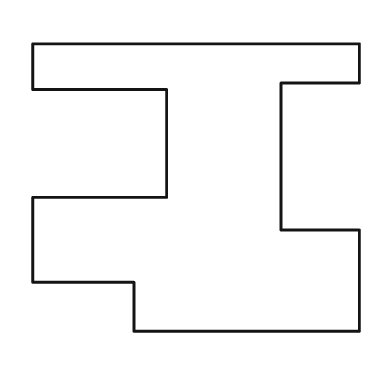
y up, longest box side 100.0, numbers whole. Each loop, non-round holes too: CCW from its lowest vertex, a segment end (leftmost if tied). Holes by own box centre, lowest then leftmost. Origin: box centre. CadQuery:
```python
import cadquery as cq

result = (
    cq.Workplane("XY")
    .moveTo(-19.0, -44.0)
    .lineTo(50.0, -44.0)
    .lineTo(50.0, -13.0)
    .lineTo(26.0, -13.0)
    .lineTo(26.0, 32.0)
    .lineTo(50.0, 32.0)
    .lineTo(50.0, 44.0)
    .lineTo(-50.0, 44.0)
    .lineTo(-50.0, 30.0)
    .lineTo(-9.0, 30.0)
    .lineTo(-9.0, -3.0)
    .lineTo(-50.0, -3.0)
    .lineTo(-50.0, -29.0)
    .lineTo(-19.0, -29.0)
    .close()
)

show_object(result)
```